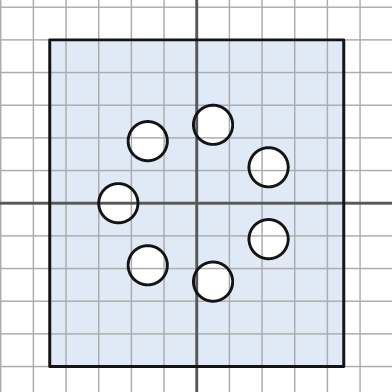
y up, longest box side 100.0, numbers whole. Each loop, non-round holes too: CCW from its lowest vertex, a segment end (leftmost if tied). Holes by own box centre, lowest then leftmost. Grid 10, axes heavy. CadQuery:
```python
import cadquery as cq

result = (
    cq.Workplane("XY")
    .moveTo(-45.0, -50.0)
    .lineTo(45.0, -50.0)
    .lineTo(45.0, 50.0)
    .lineTo(-45.0, 50.0)
    .close()
    .moveTo(5.0, -24.0)
    .circle(6.0)
    .moveTo(-15.0, -19.0)
    .circle(6.0)
    .moveTo(22.0, -11.0)
    .circle(6.0)
    .moveTo(-24.0, 0.0)
    .circle(6.0)
    .moveTo(22.0, 11.0)
    .circle(6.0)
    .moveTo(-15.0, 19.0)
    .circle(6.0)
    .moveTo(5.0, 24.0)
    .circle(6.0)
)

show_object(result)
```